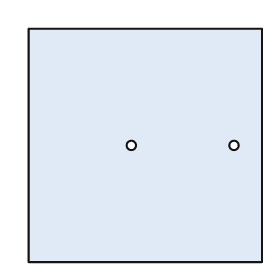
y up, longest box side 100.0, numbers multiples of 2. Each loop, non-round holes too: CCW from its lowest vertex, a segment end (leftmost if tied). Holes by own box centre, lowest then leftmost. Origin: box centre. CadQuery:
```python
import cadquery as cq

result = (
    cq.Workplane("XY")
    .moveTo(-50.0, -50.0)
    .lineTo(50.0, -50.0)
    .lineTo(50.0, 50.0)
    .lineTo(-50.0, 50.0)
    .close()
    .moveTo(-6.0, 0.0)
    .circle(2.0)
    .moveTo(38.0, 0.0)
    .circle(2.0)
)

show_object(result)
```